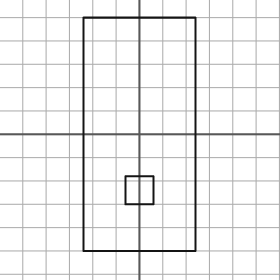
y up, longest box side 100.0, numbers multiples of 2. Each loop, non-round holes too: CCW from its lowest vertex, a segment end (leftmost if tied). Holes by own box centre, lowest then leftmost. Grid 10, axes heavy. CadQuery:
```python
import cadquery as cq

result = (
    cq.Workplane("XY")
    .moveTo(-24.0, -50.0)
    .lineTo(24.0, -50.0)
    .lineTo(24.0, 50.0)
    .lineTo(-24.0, 50.0)
    .close()
    .moveTo(-6.0, -30.0)
    .lineTo(6.0, -30.0)
    .lineTo(6.0, -18.0)
    .lineTo(-6.0, -18.0)
    .close()
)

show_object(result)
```